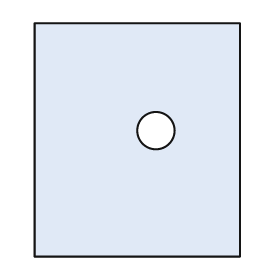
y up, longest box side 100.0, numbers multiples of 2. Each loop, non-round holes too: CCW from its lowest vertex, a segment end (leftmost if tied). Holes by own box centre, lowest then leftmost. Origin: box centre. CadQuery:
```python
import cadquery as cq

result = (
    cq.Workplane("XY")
    .moveTo(-44.0, -50.0)
    .lineTo(44.0, -50.0)
    .lineTo(44.0, 50.0)
    .lineTo(-44.0, 50.0)
    .close()
    .moveTo(8.0, 4.0)
    .circle(8.0)
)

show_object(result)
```